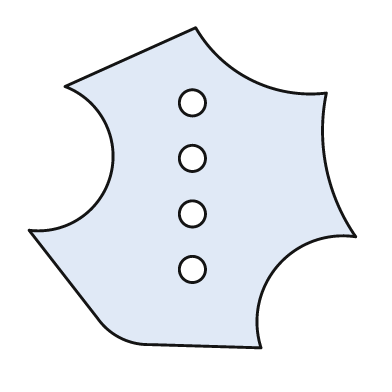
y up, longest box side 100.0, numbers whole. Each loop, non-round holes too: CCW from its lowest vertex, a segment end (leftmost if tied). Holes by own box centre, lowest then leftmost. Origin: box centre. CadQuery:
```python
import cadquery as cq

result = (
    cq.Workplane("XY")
    .moveTo(21.0, -49.0)
    .threePointArc((26.0, -24.0), (50.0, -15.0))
    .threePointArc((41.0, 6.0), (41.0, 29.0))
    .threePointArc((18.0, 33.0), (1.0, 49.0))
    .lineTo(-39.0, 31.0)
    .threePointArc((-25.0, 4.0), (-50.0, -13.0))
    .lineTo(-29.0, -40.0)
    .threePointArc((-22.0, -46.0), (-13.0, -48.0))
    .close()
    .moveTo(0.0, -25.0)
    .circle(4.0)
    .moveTo(0.0, -8.0)
    .circle(4.0)
    .moveTo(0.0, 9.0)
    .circle(4.0)
    .moveTo(0.0, 26.0)
    .circle(4.0)
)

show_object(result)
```